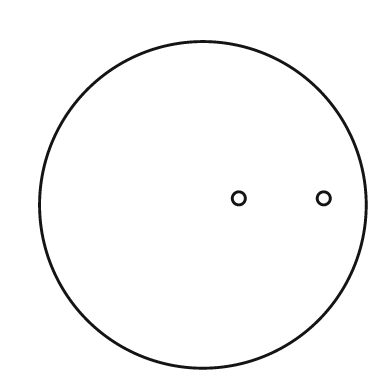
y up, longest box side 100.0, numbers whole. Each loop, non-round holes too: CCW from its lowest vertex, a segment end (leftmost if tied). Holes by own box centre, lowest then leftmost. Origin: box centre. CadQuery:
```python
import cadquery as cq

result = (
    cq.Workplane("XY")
    .moveTo(0.0, 0.0)
    .circle(50.0)
    .moveTo(11.0, 2.0)
    .circle(2.0)
    .moveTo(37.0, 2.0)
    .circle(2.0)
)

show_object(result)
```